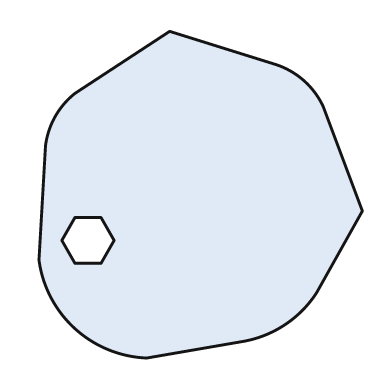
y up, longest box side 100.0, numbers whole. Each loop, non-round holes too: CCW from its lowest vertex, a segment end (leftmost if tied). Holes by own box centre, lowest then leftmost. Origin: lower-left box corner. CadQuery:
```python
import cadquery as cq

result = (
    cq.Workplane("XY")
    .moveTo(33.0, 0.0)
    .lineTo(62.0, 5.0)
    .threePointArc((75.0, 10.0), (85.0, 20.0))
    .lineTo(99.0, 45.0)
    .lineTo(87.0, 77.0)
    .threePointArc((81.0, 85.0), (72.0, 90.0))
    .lineTo(40.0, 100.0)
    .lineTo(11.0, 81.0)
    .threePointArc((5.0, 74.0), (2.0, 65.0))
    .lineTo(0.0, 30.0)
    .threePointArc((11.0, 9.0), (33.0, 0.0))
    .close()
    .moveTo(11.0, 29.0)
    .lineTo(19.0, 29.0)
    .lineTo(23.0, 36.0)
    .lineTo(19.0, 43.0)
    .lineTo(11.0, 43.0)
    .lineTo(7.0, 36.0)
    .close()
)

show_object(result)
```